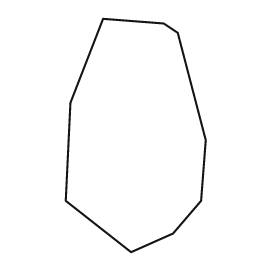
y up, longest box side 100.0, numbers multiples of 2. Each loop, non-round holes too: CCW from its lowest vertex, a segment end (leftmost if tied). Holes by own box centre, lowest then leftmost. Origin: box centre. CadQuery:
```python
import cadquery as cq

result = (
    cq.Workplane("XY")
    .moveTo(-2.0, -50.0)
    .lineTo(16.0, -42.0)
    .lineTo(28.0, -28.0)
    .lineTo(30.0, -2.0)
    .lineTo(18.0, 44.0)
    .lineTo(12.0, 48.0)
    .lineTo(-14.0, 50.0)
    .lineTo(-28.0, 14.0)
    .lineTo(-30.0, -28.0)
    .close()
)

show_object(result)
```